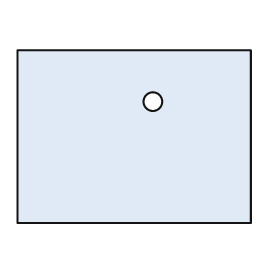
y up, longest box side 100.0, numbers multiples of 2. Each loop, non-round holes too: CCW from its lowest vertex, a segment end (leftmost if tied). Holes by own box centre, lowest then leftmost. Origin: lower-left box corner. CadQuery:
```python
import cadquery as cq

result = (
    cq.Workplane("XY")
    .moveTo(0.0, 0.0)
    .lineTo(100.0, 0.0)
    .lineTo(100.0, 74.0)
    .lineTo(0.0, 74.0)
    .close()
    .moveTo(58.0, 52.0)
    .circle(4.0)
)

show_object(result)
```